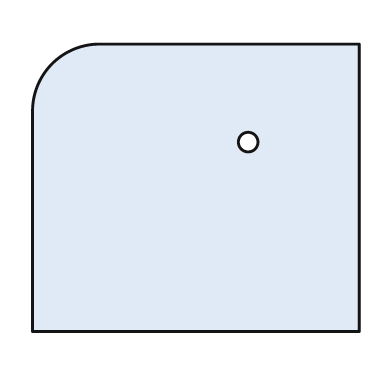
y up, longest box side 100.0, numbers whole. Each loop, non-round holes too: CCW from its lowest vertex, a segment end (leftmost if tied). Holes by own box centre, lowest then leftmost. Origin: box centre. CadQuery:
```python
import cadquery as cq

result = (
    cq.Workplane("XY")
    .moveTo(-50.0, -44.0)
    .lineTo(50.0, -44.0)
    .lineTo(50.0, 44.0)
    .lineTo(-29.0, 44.0)
    .threePointArc((-44.0, 38.0), (-50.0, 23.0))
    .close()
    .moveTo(16.0, 14.0)
    .circle(3.0)
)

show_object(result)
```